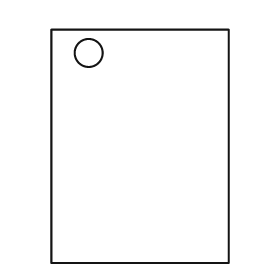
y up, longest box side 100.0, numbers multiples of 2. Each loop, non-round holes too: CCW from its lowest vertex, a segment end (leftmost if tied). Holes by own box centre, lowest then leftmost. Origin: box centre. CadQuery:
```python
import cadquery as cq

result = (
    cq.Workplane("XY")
    .moveTo(-38.0, -50.0)
    .lineTo(38.0, -50.0)
    .lineTo(38.0, 50.0)
    .lineTo(-38.0, 50.0)
    .close()
    .moveTo(-22.0, 40.0)
    .circle(6.0)
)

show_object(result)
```